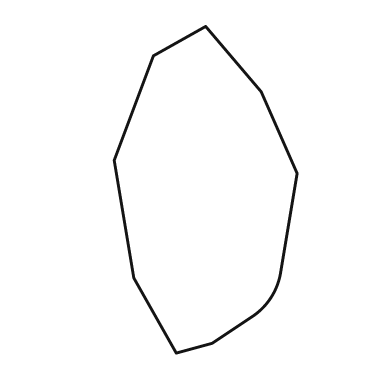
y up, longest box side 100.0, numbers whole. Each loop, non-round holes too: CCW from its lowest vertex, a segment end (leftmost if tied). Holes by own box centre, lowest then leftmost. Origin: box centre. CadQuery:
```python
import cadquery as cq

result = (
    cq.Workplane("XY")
    .moveTo(-9.0, -50.0)
    .lineTo(2.0, -47.0)
    .lineTo(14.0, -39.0)
    .threePointArc((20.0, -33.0), (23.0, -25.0))
    .lineTo(28.0, 5.0)
    .lineTo(17.0, 30.0)
    .lineTo(0.0, 50.0)
    .lineTo(-16.0, 41.0)
    .lineTo(-28.0, 9.0)
    .lineTo(-22.0, -27.0)
    .close()
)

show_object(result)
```